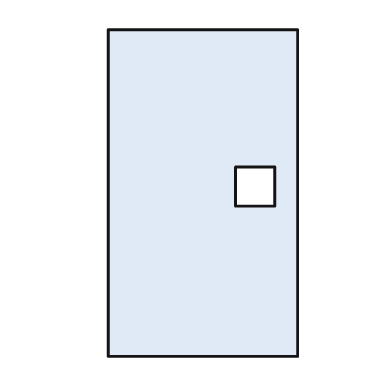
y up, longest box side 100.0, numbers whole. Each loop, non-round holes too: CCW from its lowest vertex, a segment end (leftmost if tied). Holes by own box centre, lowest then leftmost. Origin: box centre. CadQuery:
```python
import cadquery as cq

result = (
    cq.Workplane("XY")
    .moveTo(-29.0, -50.0)
    .lineTo(29.0, -50.0)
    .lineTo(29.0, 50.0)
    .lineTo(-29.0, 50.0)
    .close()
    .moveTo(10.0, -4.0)
    .lineTo(22.0, -4.0)
    .lineTo(22.0, 8.0)
    .lineTo(10.0, 8.0)
    .close()
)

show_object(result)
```